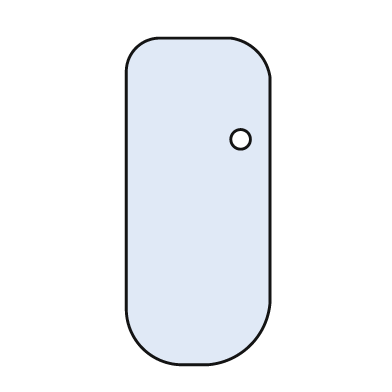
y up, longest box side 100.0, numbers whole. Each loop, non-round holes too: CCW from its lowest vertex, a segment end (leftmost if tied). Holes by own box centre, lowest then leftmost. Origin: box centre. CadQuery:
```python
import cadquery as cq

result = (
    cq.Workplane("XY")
    .moveTo(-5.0, -50.0)
    .lineTo(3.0, -50.0)
    .threePointArc((16.0, -44.0), (22.0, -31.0))
    .lineTo(22.0, 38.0)
    .threePointArc((18.0, 46.0), (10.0, 50.0))
    .lineTo(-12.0, 50.0)
    .threePointArc((-19.0, 47.0), (-22.0, 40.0))
    .lineTo(-22.0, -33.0)
    .threePointArc((-17.0, -45.0), (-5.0, -50.0))
    .close()
    .moveTo(13.0, 19.0)
    .circle(3.0)
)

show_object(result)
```